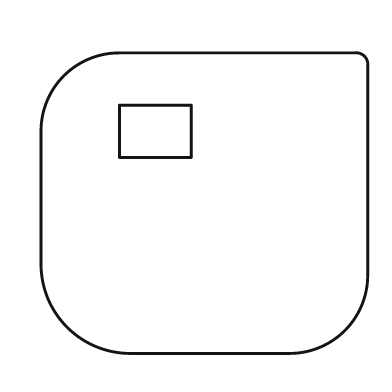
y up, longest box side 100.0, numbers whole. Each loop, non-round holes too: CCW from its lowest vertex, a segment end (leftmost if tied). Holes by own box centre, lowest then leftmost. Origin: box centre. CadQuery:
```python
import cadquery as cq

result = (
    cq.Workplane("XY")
    .moveTo(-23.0, -46.0)
    .lineTo(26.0, -46.0)
    .threePointArc((43.0, -39.0), (50.0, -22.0))
    .lineTo(50.0, 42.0)
    .threePointArc((49.0, 45.0), (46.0, 46.0))
    .lineTo(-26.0, 46.0)
    .threePointArc((-43.0, 39.0), (-50.0, 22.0))
    .lineTo(-50.0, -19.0)
    .threePointArc((-42.0, -38.0), (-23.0, -46.0))
    .close()
    .moveTo(-26.0, 14.0)
    .lineTo(-4.0, 14.0)
    .lineTo(-4.0, 30.0)
    .lineTo(-26.0, 30.0)
    .close()
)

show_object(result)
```